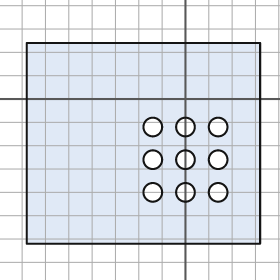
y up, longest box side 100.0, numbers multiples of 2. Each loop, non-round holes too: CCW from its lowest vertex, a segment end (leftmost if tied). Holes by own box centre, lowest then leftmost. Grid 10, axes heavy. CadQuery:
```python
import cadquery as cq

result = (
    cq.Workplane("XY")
    .moveTo(-68.0, -62.0)
    .lineTo(32.0, -62.0)
    .lineTo(32.0, 24.0)
    .lineTo(-68.0, 24.0)
    .close()
    .moveTo(-14.0, -40.0)
    .circle(4.0)
    .moveTo(0.0, -40.0)
    .circle(4.0)
    .moveTo(14.0, -40.0)
    .circle(4.0)
    .moveTo(-14.0, -26.0)
    .circle(4.0)
    .moveTo(0.0, -26.0)
    .circle(4.0)
    .moveTo(14.0, -26.0)
    .circle(4.0)
    .moveTo(-14.0, -12.0)
    .circle(4.0)
    .moveTo(0.0, -12.0)
    .circle(4.0)
    .moveTo(14.0, -12.0)
    .circle(4.0)
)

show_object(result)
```